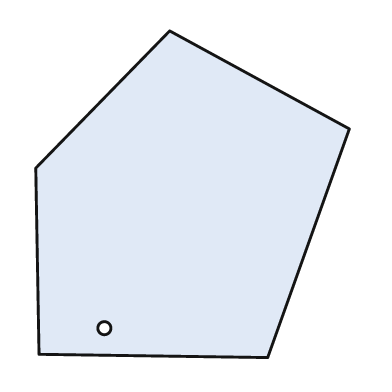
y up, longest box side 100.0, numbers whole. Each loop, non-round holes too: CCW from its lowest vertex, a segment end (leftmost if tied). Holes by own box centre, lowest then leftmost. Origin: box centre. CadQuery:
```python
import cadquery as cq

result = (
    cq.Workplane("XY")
    .moveTo(23.0, -50.0)
    .lineTo(48.0, 20.0)
    .lineTo(-7.0, 50.0)
    .lineTo(-48.0, 8.0)
    .lineTo(-47.0, -49.0)
    .close()
    .moveTo(-27.0, -41.0)
    .circle(2.0)
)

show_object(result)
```